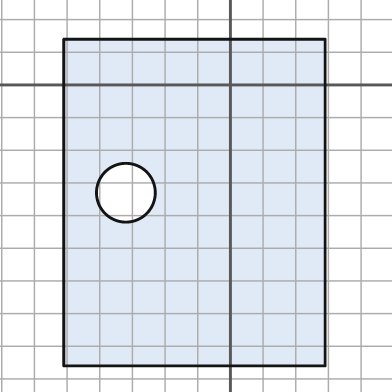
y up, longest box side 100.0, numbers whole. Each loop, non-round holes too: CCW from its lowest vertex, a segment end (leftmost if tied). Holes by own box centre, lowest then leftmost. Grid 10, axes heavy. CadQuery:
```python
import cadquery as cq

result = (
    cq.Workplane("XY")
    .moveTo(-51.0, -86.0)
    .lineTo(29.0, -86.0)
    .lineTo(29.0, 14.0)
    .lineTo(-51.0, 14.0)
    .close()
    .moveTo(-32.0, -33.0)
    .circle(9.0)
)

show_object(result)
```